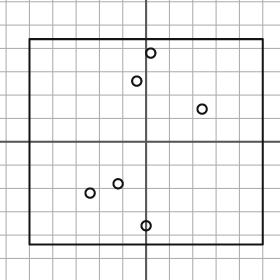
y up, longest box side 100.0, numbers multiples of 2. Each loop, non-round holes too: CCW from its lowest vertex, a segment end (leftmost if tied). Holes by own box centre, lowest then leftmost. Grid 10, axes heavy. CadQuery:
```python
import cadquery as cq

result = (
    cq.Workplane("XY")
    .moveTo(-50.0, -44.0)
    .lineTo(50.0, -44.0)
    .lineTo(50.0, 44.0)
    .lineTo(-50.0, 44.0)
    .close()
    .moveTo(0.0, -36.0)
    .circle(2.0)
    .moveTo(-24.0, -22.0)
    .circle(2.0)
    .moveTo(-12.0, -18.0)
    .circle(2.0)
    .moveTo(24.0, 14.0)
    .circle(2.0)
    .moveTo(-4.0, 26.0)
    .circle(2.0)
    .moveTo(2.0, 38.0)
    .circle(2.0)
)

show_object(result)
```